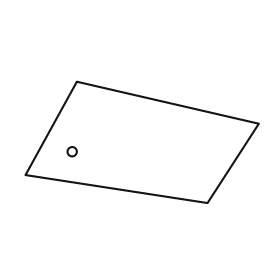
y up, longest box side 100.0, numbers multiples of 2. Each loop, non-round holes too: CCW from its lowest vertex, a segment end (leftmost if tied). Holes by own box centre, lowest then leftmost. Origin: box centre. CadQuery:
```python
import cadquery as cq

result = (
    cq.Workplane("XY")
    .moveTo(28.0, -26.0)
    .lineTo(50.0, 8.0)
    .lineTo(-28.0, 26.0)
    .lineTo(-50.0, -14.0)
    .close()
    .moveTo(-30.0, -4.0)
    .circle(2.0)
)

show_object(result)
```